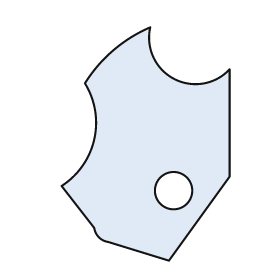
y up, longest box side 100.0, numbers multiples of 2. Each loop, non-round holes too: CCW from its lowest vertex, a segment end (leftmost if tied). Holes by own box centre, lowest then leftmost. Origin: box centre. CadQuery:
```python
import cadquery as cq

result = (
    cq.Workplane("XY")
    .moveTo(10.0, -50.0)
    .lineTo(36.0, -14.0)
    .lineTo(36.0, 32.0)
    .threePointArc((12.0, 28.0), (2.0, 50.0))
    .threePointArc((-14.0, 40.0), (-26.0, 26.0))
    .threePointArc((-22.0, 2.0), (-36.0, -18.0))
    .lineTo(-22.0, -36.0)
    .threePointArc((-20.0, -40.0), (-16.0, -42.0))
    .close()
    .moveTo(12.0, -20.0)
    .circle(8.0)
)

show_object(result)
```